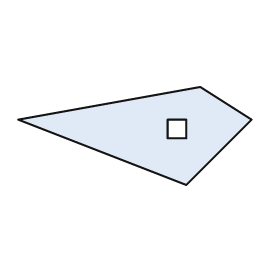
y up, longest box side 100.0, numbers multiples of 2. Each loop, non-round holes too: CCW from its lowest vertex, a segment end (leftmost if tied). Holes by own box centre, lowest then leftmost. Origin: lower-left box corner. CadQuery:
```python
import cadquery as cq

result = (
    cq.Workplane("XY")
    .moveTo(72.0, 0.0)
    .lineTo(100.0, 28.0)
    .lineTo(78.0, 42.0)
    .lineTo(0.0, 28.0)
    .close()
    .moveTo(64.0, 20.0)
    .lineTo(72.0, 20.0)
    .lineTo(72.0, 28.0)
    .lineTo(64.0, 28.0)
    .close()
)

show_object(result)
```